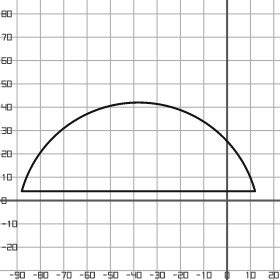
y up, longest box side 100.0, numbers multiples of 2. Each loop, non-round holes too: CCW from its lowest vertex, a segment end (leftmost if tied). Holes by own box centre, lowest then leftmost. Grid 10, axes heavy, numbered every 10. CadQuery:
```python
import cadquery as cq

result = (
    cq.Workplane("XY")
    .moveTo(-88.0, 4.0)
    .lineTo(12.0, 4.0)
    .threePointArc((-38.0, 42.0), (-88.0, 4.0))
    .close()
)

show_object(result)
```